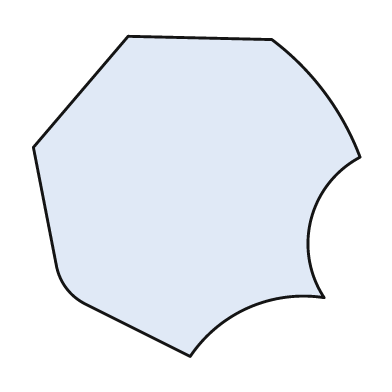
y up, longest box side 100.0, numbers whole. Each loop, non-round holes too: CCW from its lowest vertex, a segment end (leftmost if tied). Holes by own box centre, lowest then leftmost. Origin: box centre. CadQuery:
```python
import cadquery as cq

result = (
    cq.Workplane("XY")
    .moveTo(-2.0, -49.0)
    .threePointArc((16.0, -34.0), (39.0, -31.0))
    .threePointArc((35.0, -7.0), (50.0, 12.0))
    .threePointArc((39.0, 32.0), (23.0, 48.0))
    .lineTo(-21.0, 49.0)
    .lineTo(-50.0, 15.0)
    .lineTo(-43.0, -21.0)
    .threePointArc((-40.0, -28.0), (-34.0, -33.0))
    .close()
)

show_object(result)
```